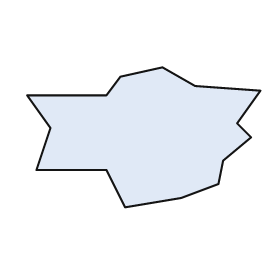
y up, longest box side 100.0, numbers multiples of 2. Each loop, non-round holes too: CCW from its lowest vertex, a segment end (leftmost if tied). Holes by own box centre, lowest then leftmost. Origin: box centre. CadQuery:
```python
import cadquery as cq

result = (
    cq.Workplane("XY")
    .moveTo(-8.0, -30.0)
    .lineTo(16.0, -26.0)
    .lineTo(32.0, -20.0)
    .lineTo(34.0, -10.0)
    .lineTo(46.0, 0.0)
    .lineTo(40.0, 6.0)
    .lineTo(50.0, 20.0)
    .lineTo(22.0, 22.0)
    .lineTo(8.0, 30.0)
    .lineTo(-10.0, 26.0)
    .lineTo(-16.0, 18.0)
    .lineTo(-50.0, 18.0)
    .lineTo(-40.0, 4.0)
    .lineTo(-46.0, -14.0)
    .lineTo(-16.0, -14.0)
    .close()
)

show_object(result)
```